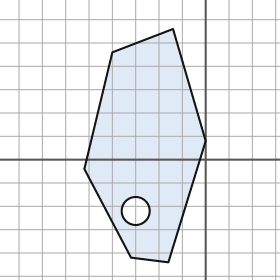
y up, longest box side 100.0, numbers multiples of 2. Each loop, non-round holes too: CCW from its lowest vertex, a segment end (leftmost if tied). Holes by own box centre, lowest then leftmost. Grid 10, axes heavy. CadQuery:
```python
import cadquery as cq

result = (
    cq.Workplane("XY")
    .moveTo(-16.0, -44.0)
    .lineTo(0.0, 8.0)
    .lineTo(-14.0, 56.0)
    .lineTo(-40.0, 46.0)
    .lineTo(-52.0, -4.0)
    .lineTo(-32.0, -42.0)
    .close()
    .moveTo(-30.0, -22.0)
    .circle(6.0)
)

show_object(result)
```